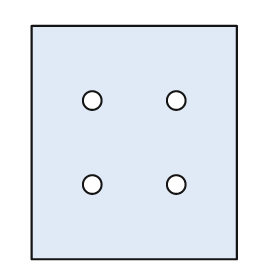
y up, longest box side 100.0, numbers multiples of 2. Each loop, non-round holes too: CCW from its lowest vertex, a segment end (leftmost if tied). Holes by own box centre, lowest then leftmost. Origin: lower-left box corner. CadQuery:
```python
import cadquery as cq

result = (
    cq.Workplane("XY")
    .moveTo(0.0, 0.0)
    .lineTo(88.0, 0.0)
    .lineTo(88.0, 100.0)
    .lineTo(0.0, 100.0)
    .close()
    .moveTo(26.0, 32.0)
    .circle(4.0)
    .moveTo(62.0, 32.0)
    .circle(4.0)
    .moveTo(26.0, 68.0)
    .circle(4.0)
    .moveTo(62.0, 68.0)
    .circle(4.0)
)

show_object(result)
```